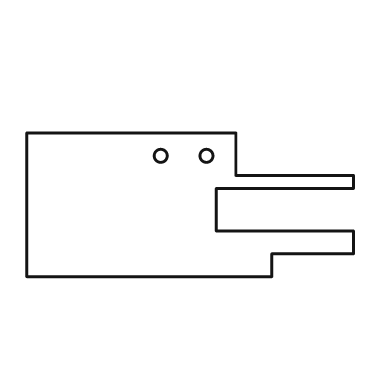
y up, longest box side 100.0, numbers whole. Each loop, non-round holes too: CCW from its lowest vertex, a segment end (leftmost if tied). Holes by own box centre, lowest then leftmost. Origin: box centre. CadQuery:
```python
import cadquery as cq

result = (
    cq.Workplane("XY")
    .moveTo(-50.0, -22.0)
    .lineTo(25.0, -22.0)
    .lineTo(25.0, -15.0)
    .lineTo(50.0, -15.0)
    .lineTo(50.0, -8.0)
    .lineTo(8.0, -8.0)
    .lineTo(8.0, 5.0)
    .lineTo(50.0, 5.0)
    .lineTo(50.0, 9.0)
    .lineTo(14.0, 9.0)
    .lineTo(14.0, 22.0)
    .lineTo(-50.0, 22.0)
    .close()
    .moveTo(-9.0, 15.0)
    .circle(2.0)
    .moveTo(5.0, 15.0)
    .circle(2.0)
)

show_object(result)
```